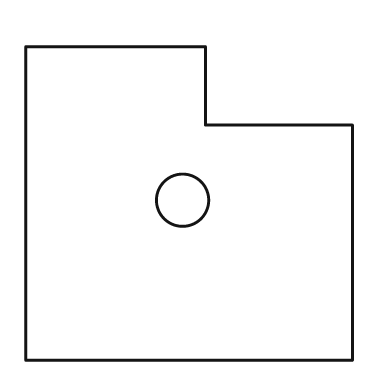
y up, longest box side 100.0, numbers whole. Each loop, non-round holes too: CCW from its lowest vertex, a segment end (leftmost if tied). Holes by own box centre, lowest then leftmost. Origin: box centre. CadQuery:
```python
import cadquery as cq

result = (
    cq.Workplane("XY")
    .moveTo(-50.0, -48.0)
    .lineTo(50.0, -48.0)
    .lineTo(50.0, 24.0)
    .lineTo(5.0, 24.0)
    .lineTo(5.0, 48.0)
    .lineTo(-50.0, 48.0)
    .close()
    .moveTo(-2.0, 1.0)
    .circle(8.0)
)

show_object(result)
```